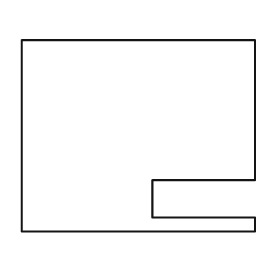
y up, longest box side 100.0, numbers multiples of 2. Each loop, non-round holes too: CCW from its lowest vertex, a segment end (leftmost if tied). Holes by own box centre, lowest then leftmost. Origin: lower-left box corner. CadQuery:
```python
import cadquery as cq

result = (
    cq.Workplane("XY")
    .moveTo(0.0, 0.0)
    .lineTo(100.0, 0.0)
    .lineTo(100.0, 6.0)
    .lineTo(56.0, 6.0)
    .lineTo(56.0, 22.0)
    .lineTo(100.0, 22.0)
    .lineTo(100.0, 82.0)
    .lineTo(0.0, 82.0)
    .close()
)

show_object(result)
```